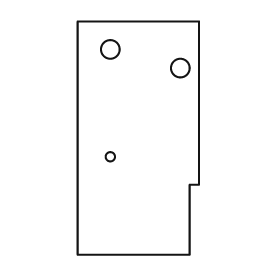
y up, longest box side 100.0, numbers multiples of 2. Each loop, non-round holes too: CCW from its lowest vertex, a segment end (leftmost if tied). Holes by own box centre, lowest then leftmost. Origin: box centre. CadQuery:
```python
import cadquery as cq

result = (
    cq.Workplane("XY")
    .moveTo(-26.0, -50.0)
    .lineTo(22.0, -50.0)
    .lineTo(22.0, -20.0)
    .lineTo(26.0, -20.0)
    .lineTo(26.0, 50.0)
    .lineTo(-26.0, 50.0)
    .close()
    .moveTo(-12.0, -8.0)
    .circle(2.0)
    .moveTo(18.0, 30.0)
    .circle(4.0)
    .moveTo(-12.0, 38.0)
    .circle(4.0)
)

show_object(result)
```